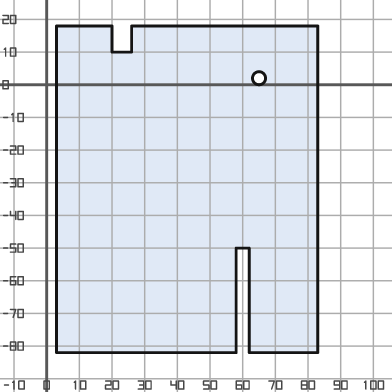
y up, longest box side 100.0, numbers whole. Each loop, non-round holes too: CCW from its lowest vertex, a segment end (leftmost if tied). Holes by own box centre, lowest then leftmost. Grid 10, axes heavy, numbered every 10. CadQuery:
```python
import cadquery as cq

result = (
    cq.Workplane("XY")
    .moveTo(3.0, -82.0)
    .lineTo(58.0, -82.0)
    .lineTo(58.0, -50.0)
    .lineTo(62.0, -50.0)
    .lineTo(62.0, -82.0)
    .lineTo(83.0, -82.0)
    .lineTo(83.0, 18.0)
    .lineTo(26.0, 18.0)
    .lineTo(26.0, 10.0)
    .lineTo(20.0, 10.0)
    .lineTo(20.0, 18.0)
    .lineTo(3.0, 18.0)
    .close()
    .moveTo(65.0, 2.0)
    .circle(2.0)
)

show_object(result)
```